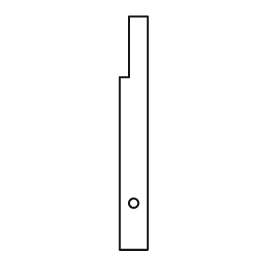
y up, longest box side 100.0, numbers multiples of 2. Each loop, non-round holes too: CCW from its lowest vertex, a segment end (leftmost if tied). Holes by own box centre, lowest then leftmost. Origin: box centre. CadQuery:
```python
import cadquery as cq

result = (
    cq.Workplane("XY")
    .moveTo(-6.0, -50.0)
    .lineTo(6.0, -50.0)
    .lineTo(6.0, 50.0)
    .lineTo(-2.0, 50.0)
    .lineTo(-2.0, 24.0)
    .lineTo(-6.0, 24.0)
    .close()
    .moveTo(0.0, -30.0)
    .circle(2.0)
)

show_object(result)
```